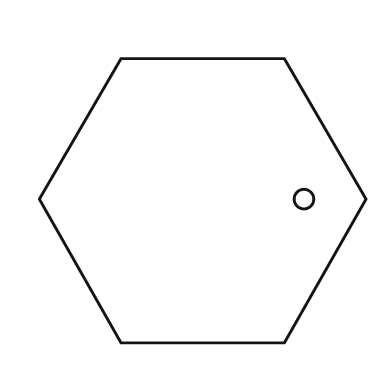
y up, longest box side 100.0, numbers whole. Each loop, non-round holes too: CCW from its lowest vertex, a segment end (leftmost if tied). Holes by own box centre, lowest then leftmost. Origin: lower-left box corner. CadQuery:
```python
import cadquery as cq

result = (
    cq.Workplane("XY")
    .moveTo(25.0, 0.0)
    .lineTo(75.0, 0.0)
    .lineTo(100.0, 44.0)
    .lineTo(75.0, 87.0)
    .lineTo(25.0, 87.0)
    .lineTo(0.0, 44.0)
    .close()
    .moveTo(81.0, 44.0)
    .circle(3.0)
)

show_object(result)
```